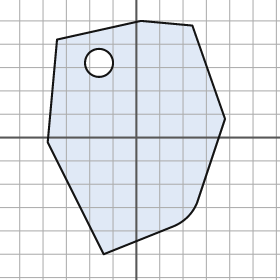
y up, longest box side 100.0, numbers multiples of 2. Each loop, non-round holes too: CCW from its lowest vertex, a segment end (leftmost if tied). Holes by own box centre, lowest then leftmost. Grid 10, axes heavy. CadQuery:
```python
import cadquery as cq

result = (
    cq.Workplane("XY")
    .moveTo(-14.0, -50.0)
    .lineTo(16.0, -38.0)
    .threePointArc((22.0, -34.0), (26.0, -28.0))
    .lineTo(38.0, 8.0)
    .lineTo(24.0, 48.0)
    .lineTo(2.0, 50.0)
    .lineTo(-34.0, 42.0)
    .lineTo(-38.0, -2.0)
    .close()
    .moveTo(-16.0, 32.0)
    .circle(6.0)
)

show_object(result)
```